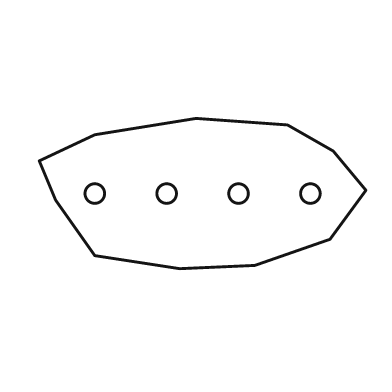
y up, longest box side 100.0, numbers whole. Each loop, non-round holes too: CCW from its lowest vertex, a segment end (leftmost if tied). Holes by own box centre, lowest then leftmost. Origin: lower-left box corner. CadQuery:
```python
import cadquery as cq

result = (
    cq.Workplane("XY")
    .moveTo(43.0, 0.0)
    .lineTo(66.0, 1.0)
    .lineTo(89.0, 9.0)
    .lineTo(100.0, 24.0)
    .lineTo(90.0, 36.0)
    .lineTo(76.0, 44.0)
    .lineTo(48.0, 46.0)
    .lineTo(17.0, 41.0)
    .lineTo(0.0, 33.0)
    .lineTo(5.0, 21.0)
    .lineTo(17.0, 4.0)
    .close()
    .moveTo(17.0, 23.0)
    .circle(3.0)
    .moveTo(39.0, 23.0)
    .circle(3.0)
    .moveTo(61.0, 23.0)
    .circle(3.0)
    .moveTo(83.0, 23.0)
    .circle(3.0)
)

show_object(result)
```